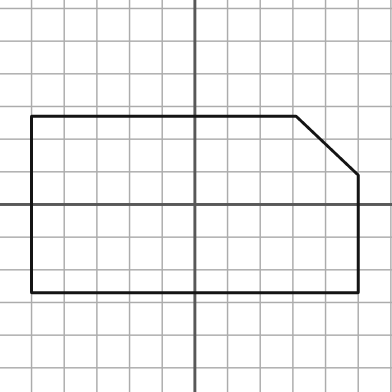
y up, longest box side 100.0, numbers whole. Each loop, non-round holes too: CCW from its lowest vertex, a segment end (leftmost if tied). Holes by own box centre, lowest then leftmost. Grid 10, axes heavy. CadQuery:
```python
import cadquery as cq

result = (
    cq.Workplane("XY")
    .moveTo(-50.0, -27.0)
    .lineTo(50.0, -27.0)
    .lineTo(50.0, 9.0)
    .lineTo(31.0, 27.0)
    .lineTo(-50.0, 27.0)
    .close()
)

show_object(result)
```